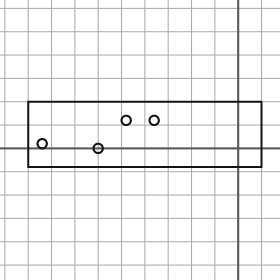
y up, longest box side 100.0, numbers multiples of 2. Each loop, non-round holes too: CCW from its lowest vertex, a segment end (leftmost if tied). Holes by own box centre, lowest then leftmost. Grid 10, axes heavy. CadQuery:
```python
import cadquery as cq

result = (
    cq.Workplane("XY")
    .moveTo(-90.0, -8.0)
    .lineTo(10.0, -8.0)
    .lineTo(10.0, 20.0)
    .lineTo(-90.0, 20.0)
    .close()
    .moveTo(-60.0, 0.0)
    .circle(2.0)
    .moveTo(-84.0, 2.0)
    .circle(2.0)
    .moveTo(-48.0, 12.0)
    .circle(2.0)
    .moveTo(-36.0, 12.0)
    .circle(2.0)
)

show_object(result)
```